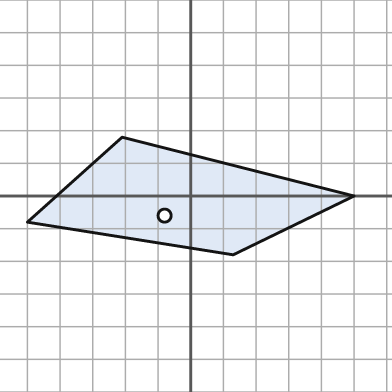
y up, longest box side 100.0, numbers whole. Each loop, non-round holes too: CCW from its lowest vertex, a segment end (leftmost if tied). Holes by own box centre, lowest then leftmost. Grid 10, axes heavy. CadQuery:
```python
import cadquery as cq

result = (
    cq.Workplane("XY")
    .moveTo(13.0, -18.0)
    .lineTo(50.0, 0.0)
    .lineTo(-21.0, 18.0)
    .lineTo(-50.0, -8.0)
    .close()
    .moveTo(-8.0, -6.0)
    .circle(2.0)
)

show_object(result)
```